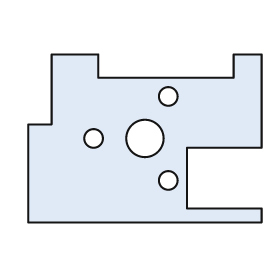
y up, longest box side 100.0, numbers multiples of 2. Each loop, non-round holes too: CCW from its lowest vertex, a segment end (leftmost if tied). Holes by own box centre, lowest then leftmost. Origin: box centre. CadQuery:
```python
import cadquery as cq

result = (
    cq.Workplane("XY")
    .moveTo(-50.0, -36.0)
    .lineTo(50.0, -36.0)
    .lineTo(50.0, -30.0)
    .lineTo(18.0, -30.0)
    .lineTo(18.0, -4.0)
    .lineTo(50.0, -4.0)
    .lineTo(50.0, 36.0)
    .lineTo(38.0, 36.0)
    .lineTo(38.0, 26.0)
    .lineTo(-20.0, 26.0)
    .lineTo(-20.0, 36.0)
    .lineTo(-40.0, 36.0)
    .lineTo(-40.0, 6.0)
    .lineTo(-50.0, 6.0)
    .close()
    .moveTo(10.0, -18.0)
    .circle(4.0)
    .moveTo(-22.0, 0.0)
    .circle(4.0)
    .moveTo(0.0, 0.0)
    .circle(8.0)
    .moveTo(10.0, 18.0)
    .circle(4.0)
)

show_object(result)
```